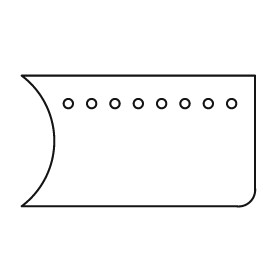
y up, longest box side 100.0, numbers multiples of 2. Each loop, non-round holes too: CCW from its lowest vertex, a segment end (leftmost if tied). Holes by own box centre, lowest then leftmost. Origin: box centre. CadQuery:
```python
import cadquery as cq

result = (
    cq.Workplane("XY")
    .moveTo(-50.0, -28.0)
    .lineTo(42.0, -28.0)
    .threePointArc((48.0, -26.0), (50.0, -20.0))
    .lineTo(50.0, 28.0)
    .lineTo(-50.0, 28.0)
    .threePointArc((-36.0, 0.0), (-50.0, -28.0))
    .close()
    .moveTo(-30.0, 16.0)
    .circle(2.0)
    .moveTo(-20.0, 16.0)
    .circle(2.0)
    .moveTo(-10.0, 16.0)
    .circle(2.0)
    .moveTo(0.0, 16.0)
    .circle(2.0)
    .moveTo(10.0, 16.0)
    .circle(2.0)
    .moveTo(20.0, 16.0)
    .circle(2.0)
    .moveTo(30.0, 16.0)
    .circle(2.0)
    .moveTo(40.0, 16.0)
    .circle(2.0)
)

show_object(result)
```